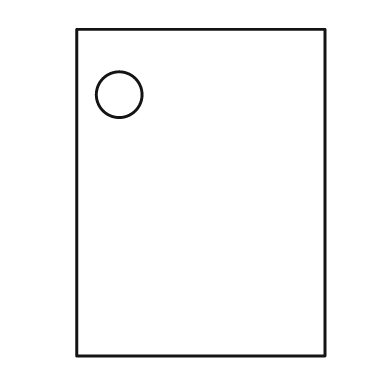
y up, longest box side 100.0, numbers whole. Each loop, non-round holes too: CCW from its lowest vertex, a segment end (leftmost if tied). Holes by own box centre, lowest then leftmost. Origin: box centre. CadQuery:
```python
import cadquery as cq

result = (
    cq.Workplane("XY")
    .moveTo(-38.0, -50.0)
    .lineTo(38.0, -50.0)
    .lineTo(38.0, 50.0)
    .lineTo(-38.0, 50.0)
    .close()
    .moveTo(-25.0, 30.0)
    .circle(7.0)
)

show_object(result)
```